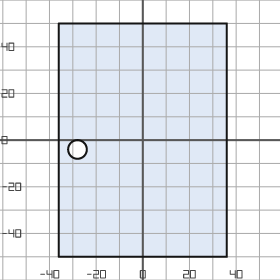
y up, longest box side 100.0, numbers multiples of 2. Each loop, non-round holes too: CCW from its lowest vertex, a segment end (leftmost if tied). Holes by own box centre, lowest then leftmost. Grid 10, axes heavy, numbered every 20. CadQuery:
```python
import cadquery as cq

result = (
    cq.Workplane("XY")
    .moveTo(-36.0, -50.0)
    .lineTo(36.0, -50.0)
    .lineTo(36.0, 50.0)
    .lineTo(-36.0, 50.0)
    .close()
    .moveTo(-28.0, -4.0)
    .circle(4.0)
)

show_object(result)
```